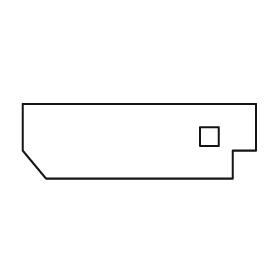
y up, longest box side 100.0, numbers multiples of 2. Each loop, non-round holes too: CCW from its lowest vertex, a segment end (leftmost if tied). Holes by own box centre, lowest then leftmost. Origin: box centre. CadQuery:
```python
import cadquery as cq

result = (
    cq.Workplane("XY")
    .moveTo(-40.0, -16.0)
    .lineTo(40.0, -16.0)
    .lineTo(40.0, -4.0)
    .lineTo(50.0, -4.0)
    .lineTo(50.0, 16.0)
    .lineTo(-50.0, 16.0)
    .lineTo(-50.0, -4.0)
    .close()
    .moveTo(26.0, -2.0)
    .lineTo(34.0, -2.0)
    .lineTo(34.0, 6.0)
    .lineTo(26.0, 6.0)
    .close()
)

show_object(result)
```